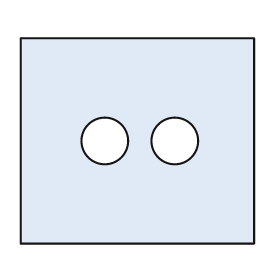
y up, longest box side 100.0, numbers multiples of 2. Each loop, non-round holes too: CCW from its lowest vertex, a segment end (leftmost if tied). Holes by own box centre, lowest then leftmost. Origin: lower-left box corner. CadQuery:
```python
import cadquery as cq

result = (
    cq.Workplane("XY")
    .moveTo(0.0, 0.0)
    .lineTo(100.0, 0.0)
    .lineTo(100.0, 88.0)
    .lineTo(0.0, 88.0)
    .close()
    .moveTo(36.0, 44.0)
    .circle(10.0)
    .moveTo(66.0, 44.0)
    .circle(10.0)
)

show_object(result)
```